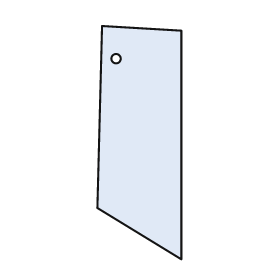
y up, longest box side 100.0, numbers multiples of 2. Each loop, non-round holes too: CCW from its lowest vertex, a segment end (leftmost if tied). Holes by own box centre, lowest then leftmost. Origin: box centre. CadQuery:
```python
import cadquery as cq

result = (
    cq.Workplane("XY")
    .moveTo(18.0, -50.0)
    .lineTo(18.0, 48.0)
    .lineTo(-16.0, 50.0)
    .lineTo(-18.0, -28.0)
    .close()
    .moveTo(-10.0, 36.0)
    .circle(2.0)
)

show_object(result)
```